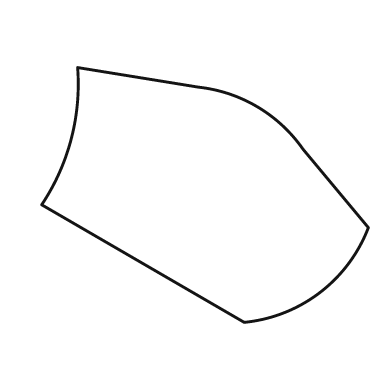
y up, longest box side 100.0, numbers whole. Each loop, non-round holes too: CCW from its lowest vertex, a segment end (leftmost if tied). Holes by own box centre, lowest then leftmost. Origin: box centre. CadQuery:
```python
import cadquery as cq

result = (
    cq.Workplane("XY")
    .moveTo(12.0, -39.0)
    .threePointArc((35.0, -30.0), (50.0, -10.0))
    .lineTo(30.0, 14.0)
    .threePointArc((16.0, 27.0), (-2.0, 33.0))
    .lineTo(-39.0, 39.0)
    .threePointArc((-41.0, 17.0), (-50.0, -3.0))
    .close()
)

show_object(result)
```